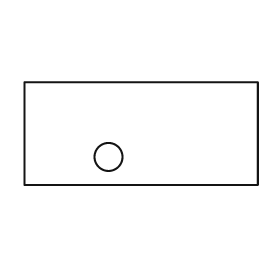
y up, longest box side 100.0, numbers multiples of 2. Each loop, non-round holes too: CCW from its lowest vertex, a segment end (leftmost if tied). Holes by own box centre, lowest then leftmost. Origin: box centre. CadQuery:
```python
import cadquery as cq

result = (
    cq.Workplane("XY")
    .moveTo(-50.0, -22.0)
    .lineTo(50.0, -22.0)
    .lineTo(50.0, 22.0)
    .lineTo(-50.0, 22.0)
    .close()
    .moveTo(-14.0, -10.0)
    .circle(6.0)
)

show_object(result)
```